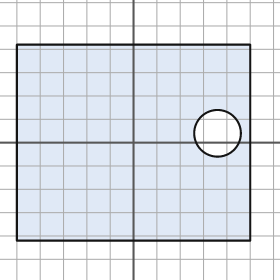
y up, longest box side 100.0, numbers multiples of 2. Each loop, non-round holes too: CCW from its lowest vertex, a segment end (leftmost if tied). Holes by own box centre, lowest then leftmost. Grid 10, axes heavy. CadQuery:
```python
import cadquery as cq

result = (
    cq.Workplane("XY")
    .moveTo(-50.0, -42.0)
    .lineTo(50.0, -42.0)
    .lineTo(50.0, 42.0)
    .lineTo(-50.0, 42.0)
    .close()
    .moveTo(36.0, 4.0)
    .circle(10.0)
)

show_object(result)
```